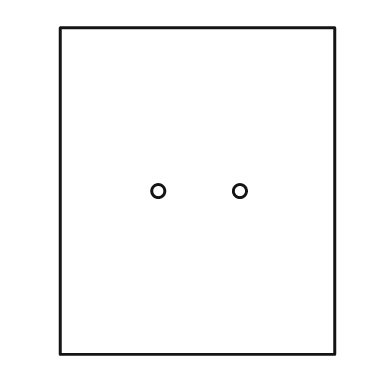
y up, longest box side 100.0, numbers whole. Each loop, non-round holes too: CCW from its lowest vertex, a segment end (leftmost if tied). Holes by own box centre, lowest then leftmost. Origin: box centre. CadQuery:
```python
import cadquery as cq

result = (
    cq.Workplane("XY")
    .moveTo(-42.0, -50.0)
    .lineTo(42.0, -50.0)
    .lineTo(42.0, 50.0)
    .lineTo(-42.0, 50.0)
    .close()
    .moveTo(-12.0, 0.0)
    .circle(2.0)
    .moveTo(13.0, 0.0)
    .circle(2.0)
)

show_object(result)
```